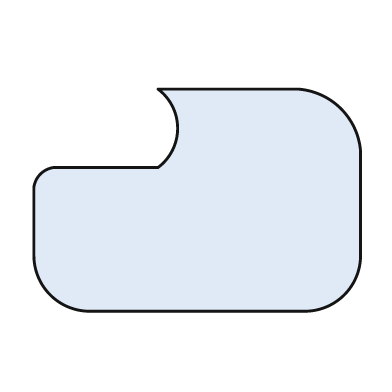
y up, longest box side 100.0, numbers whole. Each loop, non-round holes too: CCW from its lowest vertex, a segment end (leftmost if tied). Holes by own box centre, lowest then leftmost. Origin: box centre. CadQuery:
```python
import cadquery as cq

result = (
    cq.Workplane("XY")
    .moveTo(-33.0, -34.0)
    .lineTo(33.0, -34.0)
    .threePointArc((45.0, -29.0), (50.0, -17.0))
    .lineTo(50.0, 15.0)
    .threePointArc((44.0, 28.0), (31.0, 34.0))
    .lineTo(-12.0, 34.0)
    .threePointArc((-6.0, 22.0), (-12.0, 10.0))
    .lineTo(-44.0, 10.0)
    .threePointArc((-48.0, 8.0), (-50.0, 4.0))
    .lineTo(-50.0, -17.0)
    .threePointArc((-45.0, -29.0), (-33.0, -34.0))
    .close()
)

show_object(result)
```